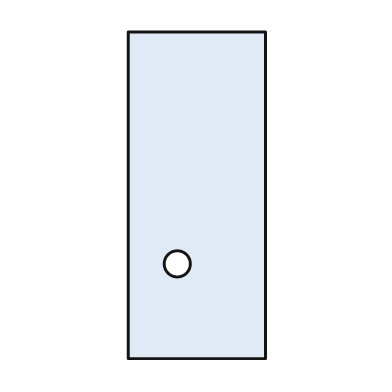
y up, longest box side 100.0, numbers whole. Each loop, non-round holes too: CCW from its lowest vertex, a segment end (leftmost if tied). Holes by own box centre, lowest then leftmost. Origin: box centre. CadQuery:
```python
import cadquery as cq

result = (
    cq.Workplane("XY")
    .moveTo(-21.0, -50.0)
    .lineTo(21.0, -50.0)
    .lineTo(21.0, 50.0)
    .lineTo(-21.0, 50.0)
    .close()
    .moveTo(-6.0, -21.0)
    .circle(4.0)
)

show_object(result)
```